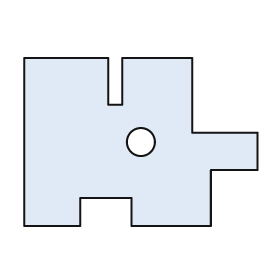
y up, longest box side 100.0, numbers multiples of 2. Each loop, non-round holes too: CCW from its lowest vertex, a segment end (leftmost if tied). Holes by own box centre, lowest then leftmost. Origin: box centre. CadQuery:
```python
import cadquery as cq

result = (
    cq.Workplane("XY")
    .moveTo(-50.0, -36.0)
    .lineTo(-26.0, -36.0)
    .lineTo(-26.0, -24.0)
    .lineTo(-4.0, -24.0)
    .lineTo(-4.0, -36.0)
    .lineTo(30.0, -36.0)
    .lineTo(30.0, -12.0)
    .lineTo(50.0, -12.0)
    .lineTo(50.0, 4.0)
    .lineTo(22.0, 4.0)
    .lineTo(22.0, 36.0)
    .lineTo(-8.0, 36.0)
    .lineTo(-8.0, 16.0)
    .lineTo(-14.0, 16.0)
    .lineTo(-14.0, 36.0)
    .lineTo(-50.0, 36.0)
    .close()
    .moveTo(0.0, 0.0)
    .circle(6.0)
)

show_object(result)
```